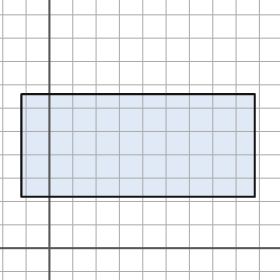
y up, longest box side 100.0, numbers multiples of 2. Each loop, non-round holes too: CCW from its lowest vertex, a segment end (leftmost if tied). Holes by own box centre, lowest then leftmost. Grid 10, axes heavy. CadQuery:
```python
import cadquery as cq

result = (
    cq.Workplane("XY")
    .moveTo(-12.0, 22.0)
    .lineTo(88.0, 22.0)
    .lineTo(88.0, 66.0)
    .lineTo(-12.0, 66.0)
    .close()
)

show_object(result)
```